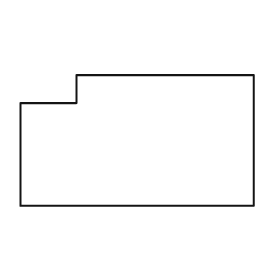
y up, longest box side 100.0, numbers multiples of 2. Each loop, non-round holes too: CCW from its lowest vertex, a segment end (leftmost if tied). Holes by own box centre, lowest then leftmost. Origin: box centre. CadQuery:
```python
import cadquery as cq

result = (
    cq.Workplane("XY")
    .moveTo(-50.0, -28.0)
    .lineTo(50.0, -28.0)
    .lineTo(50.0, 28.0)
    .lineTo(-26.0, 28.0)
    .lineTo(-26.0, 16.0)
    .lineTo(-50.0, 16.0)
    .close()
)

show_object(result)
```